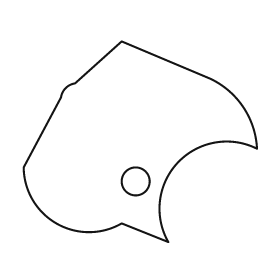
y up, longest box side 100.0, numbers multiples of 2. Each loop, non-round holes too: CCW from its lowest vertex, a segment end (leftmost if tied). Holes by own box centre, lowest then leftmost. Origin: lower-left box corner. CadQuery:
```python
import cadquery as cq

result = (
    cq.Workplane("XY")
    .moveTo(62.0, 0.0)
    .threePointArc((66.0, 34.0), (100.0, 40.0))
    .threePointArc((94.0, 58.0), (80.0, 70.0))
    .lineTo(42.0, 86.0)
    .lineTo(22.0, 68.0)
    .threePointArc((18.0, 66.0), (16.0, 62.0))
    .lineTo(0.0, 32.0)
    .threePointArc((14.0, 8.0), (42.0, 8.0))
    .close()
    .moveTo(48.0, 26.0)
    .circle(6.0)
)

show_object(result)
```